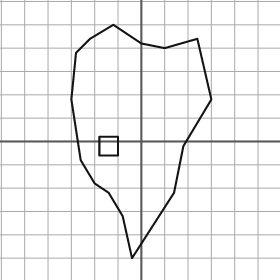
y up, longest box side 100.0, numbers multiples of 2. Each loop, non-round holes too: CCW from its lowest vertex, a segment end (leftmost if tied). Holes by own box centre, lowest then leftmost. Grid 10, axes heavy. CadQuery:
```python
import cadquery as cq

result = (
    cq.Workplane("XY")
    .moveTo(-4.0, -50.0)
    .lineTo(14.0, -22.0)
    .lineTo(18.0, -2.0)
    .lineTo(30.0, 18.0)
    .lineTo(24.0, 44.0)
    .lineTo(10.0, 40.0)
    .lineTo(0.0, 42.0)
    .lineTo(-12.0, 50.0)
    .lineTo(-22.0, 44.0)
    .lineTo(-28.0, 38.0)
    .lineTo(-30.0, 18.0)
    .lineTo(-26.0, -8.0)
    .lineTo(-20.0, -18.0)
    .lineTo(-14.0, -22.0)
    .lineTo(-8.0, -32.0)
    .close()
    .moveTo(-18.0, -6.0)
    .lineTo(-10.0, -6.0)
    .lineTo(-10.0, 2.0)
    .lineTo(-18.0, 2.0)
    .close()
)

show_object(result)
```